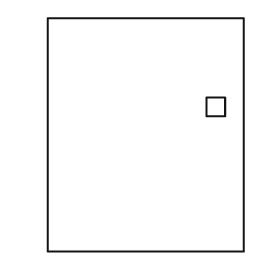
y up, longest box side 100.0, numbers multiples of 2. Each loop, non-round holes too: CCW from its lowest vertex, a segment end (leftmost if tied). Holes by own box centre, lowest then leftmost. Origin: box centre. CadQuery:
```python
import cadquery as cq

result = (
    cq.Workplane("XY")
    .moveTo(-42.0, -50.0)
    .lineTo(42.0, -50.0)
    .lineTo(42.0, 50.0)
    .lineTo(-42.0, 50.0)
    .close()
    .moveTo(26.0, 8.0)
    .lineTo(34.0, 8.0)
    .lineTo(34.0, 16.0)
    .lineTo(26.0, 16.0)
    .close()
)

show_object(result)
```